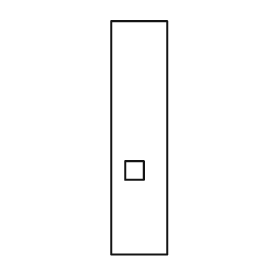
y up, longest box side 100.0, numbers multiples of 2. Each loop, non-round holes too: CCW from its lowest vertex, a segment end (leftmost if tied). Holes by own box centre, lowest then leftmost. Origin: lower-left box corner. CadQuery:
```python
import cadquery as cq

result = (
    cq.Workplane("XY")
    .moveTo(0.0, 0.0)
    .lineTo(24.0, 0.0)
    .lineTo(24.0, 100.0)
    .lineTo(0.0, 100.0)
    .close()
    .moveTo(6.0, 32.0)
    .lineTo(14.0, 32.0)
    .lineTo(14.0, 40.0)
    .lineTo(6.0, 40.0)
    .close()
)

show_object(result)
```